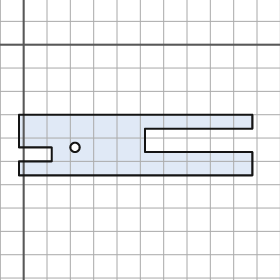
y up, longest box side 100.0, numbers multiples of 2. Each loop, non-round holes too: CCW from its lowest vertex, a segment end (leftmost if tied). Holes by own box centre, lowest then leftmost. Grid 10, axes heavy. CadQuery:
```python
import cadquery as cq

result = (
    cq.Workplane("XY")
    .moveTo(-2.0, -56.0)
    .lineTo(98.0, -56.0)
    .lineTo(98.0, -46.0)
    .lineTo(52.0, -46.0)
    .lineTo(52.0, -36.0)
    .lineTo(98.0, -36.0)
    .lineTo(98.0, -30.0)
    .lineTo(-2.0, -30.0)
    .lineTo(-2.0, -44.0)
    .lineTo(12.0, -44.0)
    .lineTo(12.0, -50.0)
    .lineTo(-2.0, -50.0)
    .close()
    .moveTo(22.0, -44.0)
    .circle(2.0)
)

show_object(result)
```